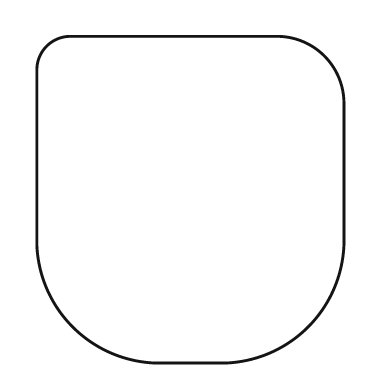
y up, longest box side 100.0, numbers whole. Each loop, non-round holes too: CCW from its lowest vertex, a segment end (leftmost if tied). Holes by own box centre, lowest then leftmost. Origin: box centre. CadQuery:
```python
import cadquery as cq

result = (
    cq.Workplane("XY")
    .moveTo(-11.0, -50.0)
    .lineTo(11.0, -50.0)
    .threePointArc((36.0, -39.0), (47.0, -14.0))
    .lineTo(47.0, 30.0)
    .threePointArc((41.0, 44.0), (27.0, 50.0))
    .lineTo(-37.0, 50.0)
    .threePointArc((-44.0, 47.0), (-47.0, 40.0))
    .lineTo(-47.0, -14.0)
    .threePointArc((-36.0, -39.0), (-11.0, -50.0))
    .close()
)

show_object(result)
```